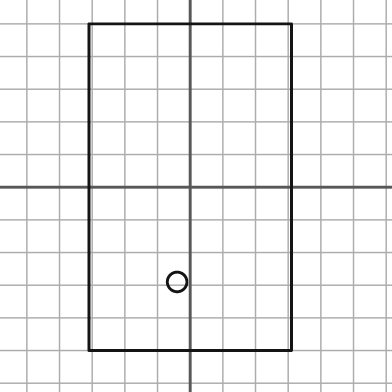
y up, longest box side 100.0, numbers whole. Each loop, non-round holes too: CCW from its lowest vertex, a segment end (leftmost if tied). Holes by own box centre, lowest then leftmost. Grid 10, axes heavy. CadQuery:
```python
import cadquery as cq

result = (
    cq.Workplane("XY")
    .moveTo(-31.0, -50.0)
    .lineTo(31.0, -50.0)
    .lineTo(31.0, 50.0)
    .lineTo(-31.0, 50.0)
    .close()
    .moveTo(-4.0, -29.0)
    .circle(3.0)
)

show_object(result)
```